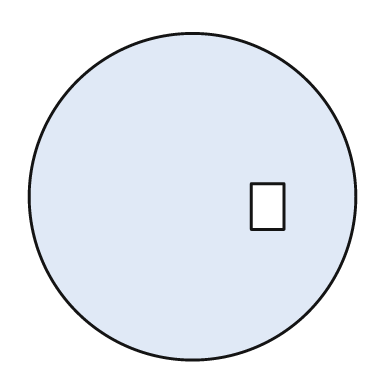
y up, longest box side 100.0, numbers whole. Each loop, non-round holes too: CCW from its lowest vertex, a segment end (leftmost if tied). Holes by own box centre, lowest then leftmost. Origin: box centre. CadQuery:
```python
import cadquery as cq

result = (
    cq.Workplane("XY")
    .moveTo(0.0, 0.0)
    .circle(50.0)
    .moveTo(18.0, -10.0)
    .lineTo(28.0, -10.0)
    .lineTo(28.0, 4.0)
    .lineTo(18.0, 4.0)
    .close()
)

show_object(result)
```